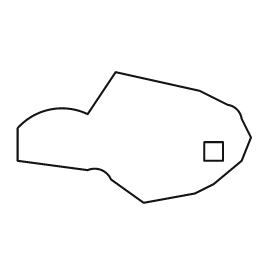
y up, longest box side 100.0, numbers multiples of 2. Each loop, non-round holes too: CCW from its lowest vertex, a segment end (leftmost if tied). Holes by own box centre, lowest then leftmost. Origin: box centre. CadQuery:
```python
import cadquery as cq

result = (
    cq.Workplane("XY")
    .moveTo(4.0, -28.0)
    .lineTo(26.0, -24.0)
    .lineTo(34.0, -20.0)
    .lineTo(46.0, -10.0)
    .lineTo(50.0, 0.0)
    .lineTo(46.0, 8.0)
    .threePointArc((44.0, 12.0), (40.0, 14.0))
    .lineTo(28.0, 20.0)
    .lineTo(-8.0, 28.0)
    .lineTo(-20.0, 10.0)
    .threePointArc((-36.0, 12.0), (-50.0, 4.0))
    .lineTo(-50.0, -10.0)
    .lineTo(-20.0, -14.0)
    .threePointArc((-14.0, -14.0), (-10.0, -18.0))
    .close()
    .moveTo(30.0, -10.0)
    .lineTo(38.0, -10.0)
    .lineTo(38.0, -2.0)
    .lineTo(30.0, -2.0)
    .close()
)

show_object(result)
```